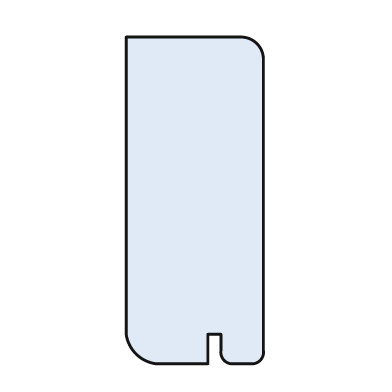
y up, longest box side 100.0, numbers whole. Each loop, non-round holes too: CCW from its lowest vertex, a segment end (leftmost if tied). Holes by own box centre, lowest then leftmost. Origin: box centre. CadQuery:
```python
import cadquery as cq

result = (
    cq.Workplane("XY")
    .moveTo(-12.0, -50.0)
    .lineTo(4.0, -50.0)
    .lineTo(4.0, -41.0)
    .lineTo(8.0, -41.0)
    .lineTo(8.0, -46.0)
    .threePointArc((9.0, -49.0), (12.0, -50.0))
    .lineTo(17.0, -50.0)
    .threePointArc((20.0, -49.0), (21.0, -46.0))
    .lineTo(21.0, 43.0)
    .threePointArc((19.0, 48.0), (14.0, 50.0))
    .lineTo(-21.0, 50.0)
    .lineTo(-21.0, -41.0)
    .threePointArc((-18.0, -47.0), (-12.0, -50.0))
    .close()
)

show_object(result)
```